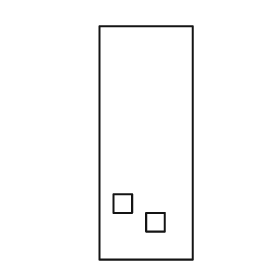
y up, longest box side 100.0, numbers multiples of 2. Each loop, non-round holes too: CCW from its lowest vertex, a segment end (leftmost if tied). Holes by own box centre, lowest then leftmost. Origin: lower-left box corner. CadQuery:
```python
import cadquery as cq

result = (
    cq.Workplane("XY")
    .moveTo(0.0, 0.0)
    .lineTo(40.0, 0.0)
    .lineTo(40.0, 100.0)
    .lineTo(0.0, 100.0)
    .close()
    .moveTo(20.0, 12.0)
    .lineTo(28.0, 12.0)
    .lineTo(28.0, 20.0)
    .lineTo(20.0, 20.0)
    .close()
    .moveTo(6.0, 20.0)
    .lineTo(14.0, 20.0)
    .lineTo(14.0, 28.0)
    .lineTo(6.0, 28.0)
    .close()
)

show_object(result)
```